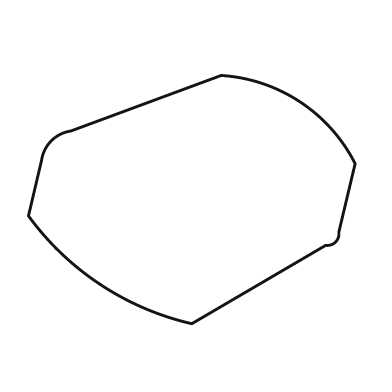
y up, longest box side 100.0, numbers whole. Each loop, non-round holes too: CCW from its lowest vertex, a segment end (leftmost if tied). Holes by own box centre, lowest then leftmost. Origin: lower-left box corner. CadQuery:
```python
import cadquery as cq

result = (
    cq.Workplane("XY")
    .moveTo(50.0, 0.0)
    .lineTo(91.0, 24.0)
    .threePointArc((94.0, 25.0), (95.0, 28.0))
    .lineTo(100.0, 49.0)
    .threePointArc((83.0, 68.0), (59.0, 76.0))
    .lineTo(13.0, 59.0)
    .threePointArc((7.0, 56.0), (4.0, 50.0))
    .lineTo(0.0, 33.0)
    .threePointArc((22.0, 12.0), (50.0, 0.0))
    .close()
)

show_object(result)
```